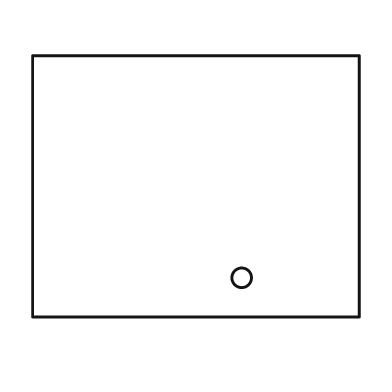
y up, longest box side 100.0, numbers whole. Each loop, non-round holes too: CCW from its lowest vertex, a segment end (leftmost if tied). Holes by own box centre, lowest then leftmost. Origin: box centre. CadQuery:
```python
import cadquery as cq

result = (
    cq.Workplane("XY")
    .moveTo(-50.0, -40.0)
    .lineTo(50.0, -40.0)
    .lineTo(50.0, 40.0)
    .lineTo(-50.0, 40.0)
    .close()
    .moveTo(14.0, -28.0)
    .circle(3.0)
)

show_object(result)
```